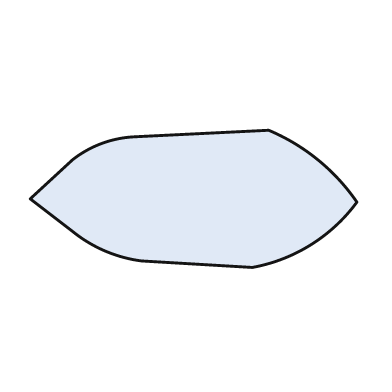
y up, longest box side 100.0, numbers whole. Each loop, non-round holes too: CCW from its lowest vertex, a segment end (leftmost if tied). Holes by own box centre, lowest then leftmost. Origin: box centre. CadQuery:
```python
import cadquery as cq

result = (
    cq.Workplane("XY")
    .moveTo(18.0, -21.0)
    .threePointArc((36.0, -14.0), (50.0, -1.0))
    .threePointArc((38.0, 12.0), (23.0, 21.0))
    .lineTo(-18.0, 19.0)
    .threePointArc((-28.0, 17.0), (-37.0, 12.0))
    .lineTo(-50.0, 0.0)
    .lineTo(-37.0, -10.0)
    .threePointArc((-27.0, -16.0), (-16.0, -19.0))
    .close()
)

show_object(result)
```